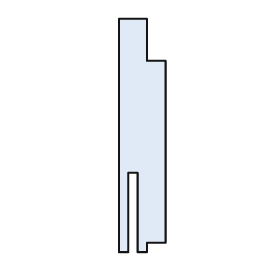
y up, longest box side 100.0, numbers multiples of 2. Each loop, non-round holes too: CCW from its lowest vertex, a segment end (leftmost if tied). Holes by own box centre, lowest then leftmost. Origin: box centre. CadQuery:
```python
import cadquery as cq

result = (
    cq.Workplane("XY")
    .moveTo(-10.0, -50.0)
    .lineTo(-6.0, -50.0)
    .lineTo(-6.0, -16.0)
    .lineTo(-2.0, -16.0)
    .lineTo(-2.0, -50.0)
    .lineTo(2.0, -50.0)
    .lineTo(2.0, -46.0)
    .lineTo(10.0, -46.0)
    .lineTo(10.0, 32.0)
    .lineTo(2.0, 32.0)
    .lineTo(2.0, 50.0)
    .lineTo(-10.0, 50.0)
    .close()
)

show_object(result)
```